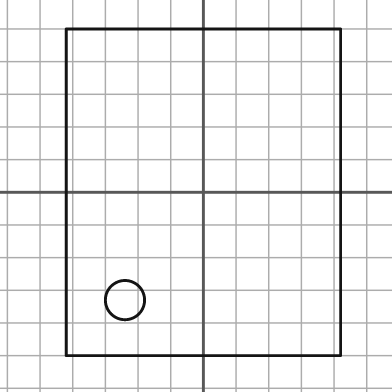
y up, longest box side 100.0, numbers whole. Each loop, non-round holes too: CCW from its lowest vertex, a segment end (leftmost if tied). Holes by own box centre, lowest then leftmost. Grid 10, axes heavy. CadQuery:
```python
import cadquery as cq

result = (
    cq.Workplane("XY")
    .moveTo(-42.0, -50.0)
    .lineTo(42.0, -50.0)
    .lineTo(42.0, 50.0)
    .lineTo(-42.0, 50.0)
    .close()
    .moveTo(-24.0, -33.0)
    .circle(6.0)
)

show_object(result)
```